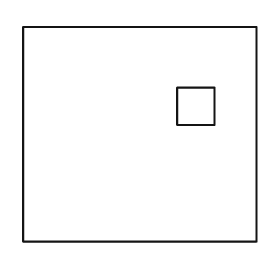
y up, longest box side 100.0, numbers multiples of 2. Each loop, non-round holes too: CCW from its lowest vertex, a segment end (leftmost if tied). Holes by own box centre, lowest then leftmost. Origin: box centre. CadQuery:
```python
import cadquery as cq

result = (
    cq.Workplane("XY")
    .moveTo(-50.0, -46.0)
    .lineTo(50.0, -46.0)
    .lineTo(50.0, 46.0)
    .lineTo(-50.0, 46.0)
    .close()
    .moveTo(16.0, 4.0)
    .lineTo(32.0, 4.0)
    .lineTo(32.0, 20.0)
    .lineTo(16.0, 20.0)
    .close()
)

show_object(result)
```